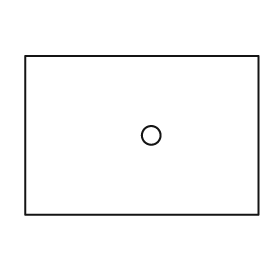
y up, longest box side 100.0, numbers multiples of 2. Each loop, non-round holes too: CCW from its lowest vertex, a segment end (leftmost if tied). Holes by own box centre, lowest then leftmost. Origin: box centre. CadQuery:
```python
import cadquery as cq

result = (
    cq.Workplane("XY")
    .moveTo(-50.0, -34.0)
    .lineTo(50.0, -34.0)
    .lineTo(50.0, 34.0)
    .lineTo(-50.0, 34.0)
    .close()
    .moveTo(4.0, 0.0)
    .circle(4.0)
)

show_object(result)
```